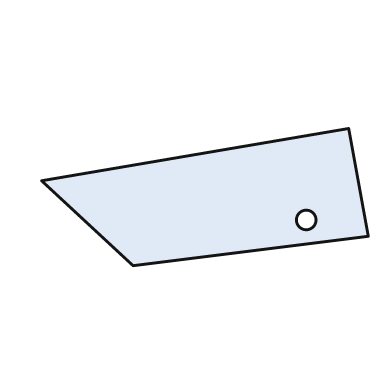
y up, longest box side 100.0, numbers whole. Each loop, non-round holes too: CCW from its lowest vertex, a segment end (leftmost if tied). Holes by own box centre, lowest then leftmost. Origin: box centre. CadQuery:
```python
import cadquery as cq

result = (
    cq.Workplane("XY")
    .moveTo(-22.0, -21.0)
    .lineTo(50.0, -12.0)
    .lineTo(44.0, 21.0)
    .lineTo(-50.0, 5.0)
    .close()
    .moveTo(31.0, -7.0)
    .circle(3.0)
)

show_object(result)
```